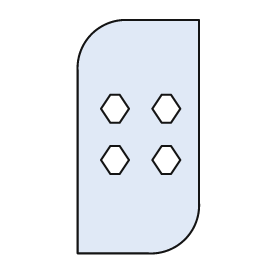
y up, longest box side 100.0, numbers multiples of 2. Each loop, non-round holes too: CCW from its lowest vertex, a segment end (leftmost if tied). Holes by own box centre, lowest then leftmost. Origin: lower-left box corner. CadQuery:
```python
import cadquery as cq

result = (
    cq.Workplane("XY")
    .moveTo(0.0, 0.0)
    .lineTo(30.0, 0.0)
    .threePointArc((46.0, 6.0), (52.0, 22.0))
    .lineTo(52.0, 100.0)
    .lineTo(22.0, 100.0)
    .threePointArc((6.0, 94.0), (0.0, 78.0))
    .close()
    .moveTo(14.0, 34.0)
    .lineTo(18.0, 34.0)
    .lineTo(22.0, 40.0)
    .lineTo(18.0, 46.0)
    .lineTo(14.0, 46.0)
    .lineTo(10.0, 40.0)
    .close()
    .moveTo(36.0, 34.0)
    .lineTo(40.0, 34.0)
    .lineTo(44.0, 40.0)
    .lineTo(40.0, 46.0)
    .lineTo(36.0, 46.0)
    .lineTo(32.0, 40.0)
    .close()
    .moveTo(14.0, 56.0)
    .lineTo(18.0, 56.0)
    .lineTo(22.0, 62.0)
    .lineTo(18.0, 68.0)
    .lineTo(14.0, 68.0)
    .lineTo(10.0, 62.0)
    .close()
    .moveTo(36.0, 56.0)
    .lineTo(40.0, 56.0)
    .lineTo(44.0, 62.0)
    .lineTo(40.0, 68.0)
    .lineTo(36.0, 68.0)
    .lineTo(32.0, 62.0)
    .close()
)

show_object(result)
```